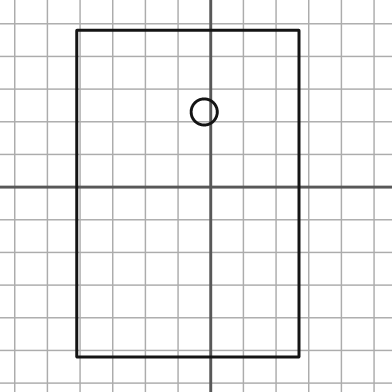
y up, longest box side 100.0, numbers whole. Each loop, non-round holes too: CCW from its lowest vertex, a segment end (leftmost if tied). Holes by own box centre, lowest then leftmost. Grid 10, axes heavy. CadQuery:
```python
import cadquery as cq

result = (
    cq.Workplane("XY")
    .moveTo(-41.0, -52.0)
    .lineTo(27.0, -52.0)
    .lineTo(27.0, 48.0)
    .lineTo(-41.0, 48.0)
    .close()
    .moveTo(-2.0, 23.0)
    .circle(4.0)
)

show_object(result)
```